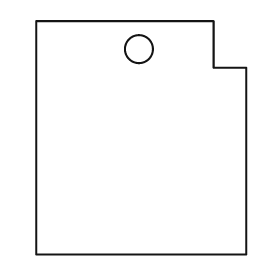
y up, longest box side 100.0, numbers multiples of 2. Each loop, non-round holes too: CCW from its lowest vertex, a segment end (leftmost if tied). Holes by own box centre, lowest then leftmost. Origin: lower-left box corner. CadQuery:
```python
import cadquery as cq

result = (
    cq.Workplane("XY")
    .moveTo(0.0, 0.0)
    .lineTo(90.0, 0.0)
    .lineTo(90.0, 80.0)
    .lineTo(76.0, 80.0)
    .lineTo(76.0, 100.0)
    .lineTo(0.0, 100.0)
    .close()
    .moveTo(44.0, 88.0)
    .circle(6.0)
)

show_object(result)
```